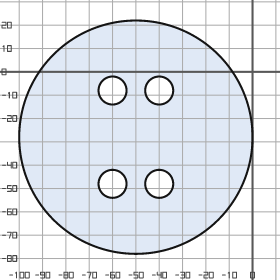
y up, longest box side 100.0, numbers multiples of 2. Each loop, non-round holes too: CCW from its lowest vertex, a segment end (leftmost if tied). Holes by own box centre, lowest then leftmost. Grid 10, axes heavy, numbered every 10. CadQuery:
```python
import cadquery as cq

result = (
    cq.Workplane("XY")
    .moveTo(-50.0, -28.0)
    .circle(50.0)
    .moveTo(-60.0, -48.0)
    .circle(6.0)
    .moveTo(-40.0, -48.0)
    .circle(6.0)
    .moveTo(-60.0, -8.0)
    .circle(6.0)
    .moveTo(-40.0, -8.0)
    .circle(6.0)
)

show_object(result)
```